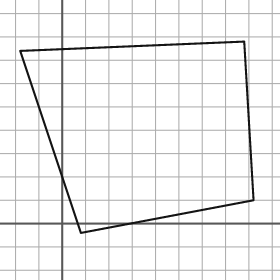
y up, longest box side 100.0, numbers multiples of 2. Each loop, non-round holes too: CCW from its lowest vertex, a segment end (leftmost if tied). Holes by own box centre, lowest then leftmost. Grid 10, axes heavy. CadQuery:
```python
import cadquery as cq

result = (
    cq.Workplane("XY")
    .moveTo(8.0, -4.0)
    .lineTo(82.0, 10.0)
    .lineTo(78.0, 78.0)
    .lineTo(-18.0, 74.0)
    .close()
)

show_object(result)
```